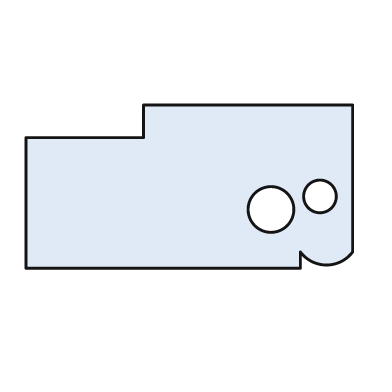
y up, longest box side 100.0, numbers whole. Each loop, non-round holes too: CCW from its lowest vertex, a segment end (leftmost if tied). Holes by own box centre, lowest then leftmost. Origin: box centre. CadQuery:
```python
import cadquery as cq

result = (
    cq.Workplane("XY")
    .moveTo(-50.0, -25.0)
    .lineTo(34.0, -25.0)
    .lineTo(34.0, -20.0)
    .threePointArc((42.0, -24.0), (50.0, -20.0))
    .lineTo(50.0, 25.0)
    .lineTo(-14.0, 25.0)
    .lineTo(-14.0, 15.0)
    .lineTo(-50.0, 15.0)
    .close()
    .moveTo(25.0, -7.0)
    .circle(7.0)
    .moveTo(40.0, -3.0)
    .circle(5.0)
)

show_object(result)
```